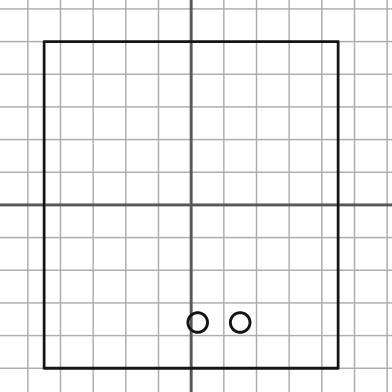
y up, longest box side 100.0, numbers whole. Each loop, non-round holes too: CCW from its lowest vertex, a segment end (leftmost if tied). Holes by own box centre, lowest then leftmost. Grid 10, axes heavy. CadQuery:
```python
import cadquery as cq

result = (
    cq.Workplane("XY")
    .moveTo(-45.0, -50.0)
    .lineTo(45.0, -50.0)
    .lineTo(45.0, 50.0)
    .lineTo(-45.0, 50.0)
    .close()
    .moveTo(2.0, -36.0)
    .circle(3.0)
    .moveTo(15.0, -36.0)
    .circle(3.0)
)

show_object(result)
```